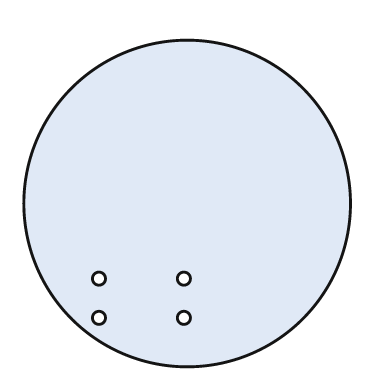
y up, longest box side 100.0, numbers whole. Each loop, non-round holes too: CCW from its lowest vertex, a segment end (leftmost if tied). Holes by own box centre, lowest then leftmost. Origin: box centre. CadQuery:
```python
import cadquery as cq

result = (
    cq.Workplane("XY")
    .moveTo(0.0, 0.0)
    .circle(50.0)
    .moveTo(-27.0, -35.0)
    .circle(2.0)
    .moveTo(-1.0, -35.0)
    .circle(2.0)
    .moveTo(-27.0, -23.0)
    .circle(2.0)
    .moveTo(-1.0, -23.0)
    .circle(2.0)
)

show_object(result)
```